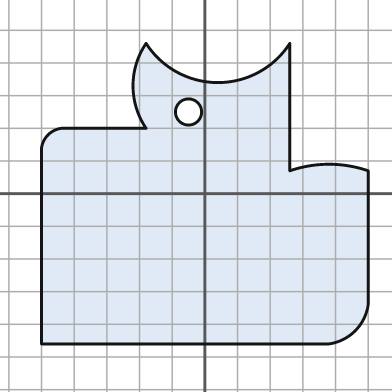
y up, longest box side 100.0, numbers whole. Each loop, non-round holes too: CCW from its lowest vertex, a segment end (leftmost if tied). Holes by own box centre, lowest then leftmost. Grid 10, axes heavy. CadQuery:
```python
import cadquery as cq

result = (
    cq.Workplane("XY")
    .moveTo(-50.0, -46.0)
    .lineTo(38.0, -46.0)
    .threePointArc((46.0, -42.0), (50.0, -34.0))
    .lineTo(50.0, 7.0)
    .threePointArc((38.0, 9.0), (26.0, 7.0))
    .lineTo(26.0, 46.0)
    .threePointArc((4.0, 34.0), (-18.0, 46.0))
    .threePointArc((-22.0, 33.0), (-18.0, 20.0))
    .lineTo(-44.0, 20.0)
    .threePointArc((-48.0, 18.0), (-50.0, 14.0))
    .close()
    .moveTo(-5.0, 25.0)
    .circle(4.0)
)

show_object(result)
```